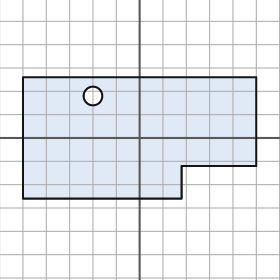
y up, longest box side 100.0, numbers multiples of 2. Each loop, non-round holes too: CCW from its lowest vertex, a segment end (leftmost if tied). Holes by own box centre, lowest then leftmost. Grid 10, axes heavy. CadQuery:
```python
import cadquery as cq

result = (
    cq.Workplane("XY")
    .moveTo(-50.0, -26.0)
    .lineTo(18.0, -26.0)
    .lineTo(18.0, -12.0)
    .lineTo(50.0, -12.0)
    .lineTo(50.0, 26.0)
    .lineTo(-50.0, 26.0)
    .close()
    .moveTo(-20.0, 18.0)
    .circle(4.0)
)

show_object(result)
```